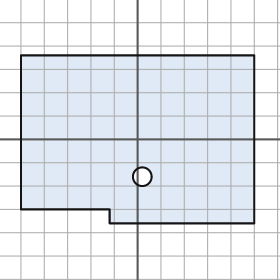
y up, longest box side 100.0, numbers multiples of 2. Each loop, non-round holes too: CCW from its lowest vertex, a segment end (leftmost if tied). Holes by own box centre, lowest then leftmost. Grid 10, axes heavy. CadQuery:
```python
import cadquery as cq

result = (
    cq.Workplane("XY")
    .moveTo(-12.0, -36.0)
    .lineTo(50.0, -36.0)
    .lineTo(50.0, 36.0)
    .lineTo(-50.0, 36.0)
    .lineTo(-50.0, -30.0)
    .lineTo(-12.0, -30.0)
    .close()
    .moveTo(2.0, -16.0)
    .circle(4.0)
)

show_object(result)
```